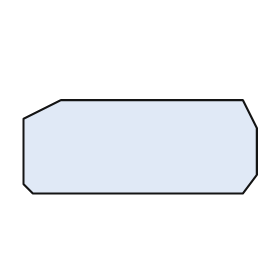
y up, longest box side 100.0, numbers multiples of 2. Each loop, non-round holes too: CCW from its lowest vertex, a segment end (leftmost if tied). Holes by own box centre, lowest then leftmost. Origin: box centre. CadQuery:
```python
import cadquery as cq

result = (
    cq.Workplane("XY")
    .moveTo(-46.0, -20.0)
    .lineTo(44.0, -20.0)
    .lineTo(50.0, -12.0)
    .lineTo(50.0, 8.0)
    .lineTo(44.0, 20.0)
    .lineTo(-34.0, 20.0)
    .lineTo(-50.0, 12.0)
    .lineTo(-50.0, -16.0)
    .close()
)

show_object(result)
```